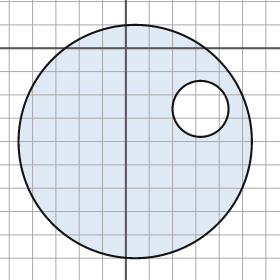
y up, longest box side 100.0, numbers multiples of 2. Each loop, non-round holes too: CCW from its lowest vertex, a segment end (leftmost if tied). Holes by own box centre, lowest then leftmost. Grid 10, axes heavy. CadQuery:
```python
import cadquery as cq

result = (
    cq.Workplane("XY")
    .moveTo(4.0, -40.0)
    .circle(50.0)
    .moveTo(32.0, -26.0)
    .circle(12.0)
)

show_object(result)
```